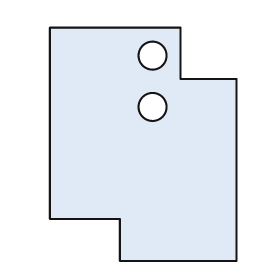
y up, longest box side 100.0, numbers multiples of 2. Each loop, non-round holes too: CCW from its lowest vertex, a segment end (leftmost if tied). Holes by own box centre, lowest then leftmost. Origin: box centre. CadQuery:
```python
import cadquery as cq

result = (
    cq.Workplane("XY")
    .moveTo(-10.0, -50.0)
    .lineTo(40.0, -50.0)
    .lineTo(40.0, 28.0)
    .lineTo(16.0, 28.0)
    .lineTo(16.0, 50.0)
    .lineTo(-40.0, 50.0)
    .lineTo(-40.0, -32.0)
    .lineTo(-10.0, -32.0)
    .close()
    .moveTo(4.0, 16.0)
    .circle(6.0)
    .moveTo(4.0, 38.0)
    .circle(6.0)
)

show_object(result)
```